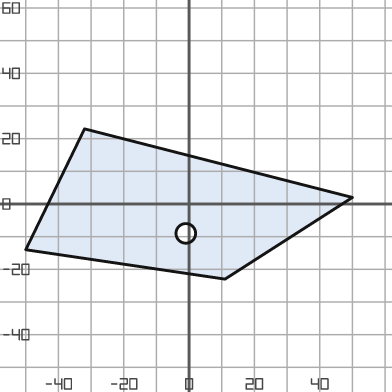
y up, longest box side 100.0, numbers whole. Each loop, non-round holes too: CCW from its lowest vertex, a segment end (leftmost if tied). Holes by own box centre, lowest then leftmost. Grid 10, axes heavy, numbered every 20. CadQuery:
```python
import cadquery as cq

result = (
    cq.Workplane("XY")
    .moveTo(11.0, -23.0)
    .lineTo(50.0, 2.0)
    .lineTo(-32.0, 23.0)
    .lineTo(-50.0, -14.0)
    .close()
    .moveTo(-1.0, -9.0)
    .circle(3.0)
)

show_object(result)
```